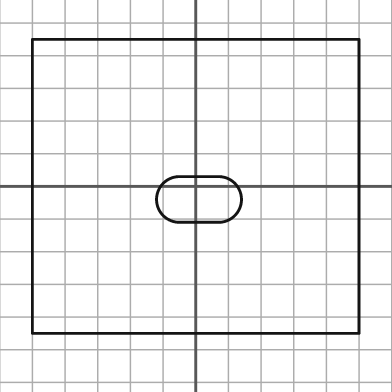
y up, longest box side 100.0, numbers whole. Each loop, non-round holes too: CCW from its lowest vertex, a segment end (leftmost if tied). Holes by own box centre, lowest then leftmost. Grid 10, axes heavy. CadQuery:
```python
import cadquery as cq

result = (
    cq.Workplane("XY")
    .moveTo(-50.0, -45.0)
    .lineTo(50.0, -45.0)
    .lineTo(50.0, 45.0)
    .lineTo(-50.0, 45.0)
    .close()
    .moveTo(-5.0, -11.0)
    .lineTo(7.0, -11.0)
    .threePointArc((14.0, -4.0), (7.0, 3.0))
    .lineTo(-5.0, 3.0)
    .threePointArc((-12.0, -4.0), (-5.0, -11.0))
    .close()
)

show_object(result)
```